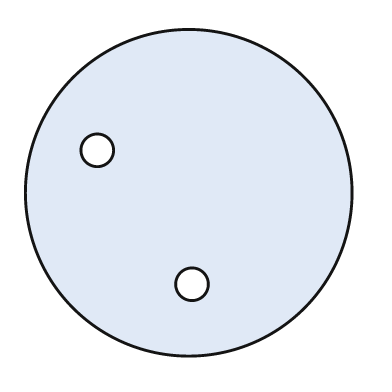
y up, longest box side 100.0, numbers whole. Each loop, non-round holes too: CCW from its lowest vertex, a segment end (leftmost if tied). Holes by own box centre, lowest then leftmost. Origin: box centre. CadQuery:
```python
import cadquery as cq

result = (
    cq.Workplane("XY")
    .moveTo(0.0, 0.0)
    .circle(50.0)
    .moveTo(1.0, -28.0)
    .circle(5.0)
    .moveTo(-28.0, 13.0)
    .circle(5.0)
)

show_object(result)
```